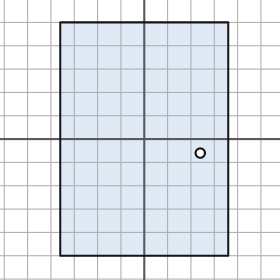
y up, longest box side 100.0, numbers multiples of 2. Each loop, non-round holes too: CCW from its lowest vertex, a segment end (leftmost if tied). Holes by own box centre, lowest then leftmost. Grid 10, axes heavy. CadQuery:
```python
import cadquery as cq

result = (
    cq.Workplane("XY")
    .moveTo(-36.0, -50.0)
    .lineTo(36.0, -50.0)
    .lineTo(36.0, 50.0)
    .lineTo(-36.0, 50.0)
    .close()
    .moveTo(24.0, -6.0)
    .circle(2.0)
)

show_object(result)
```